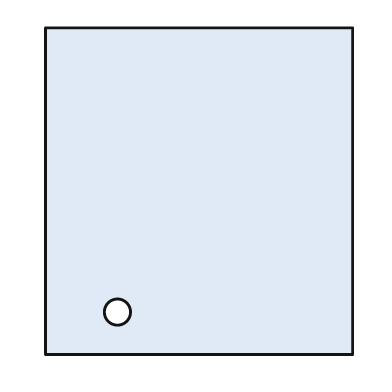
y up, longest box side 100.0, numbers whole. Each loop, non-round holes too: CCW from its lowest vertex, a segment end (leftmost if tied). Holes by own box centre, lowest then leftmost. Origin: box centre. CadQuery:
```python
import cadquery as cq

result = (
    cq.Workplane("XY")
    .moveTo(-47.0, -50.0)
    .lineTo(47.0, -50.0)
    .lineTo(47.0, 50.0)
    .lineTo(-47.0, 50.0)
    .close()
    .moveTo(-25.0, -37.0)
    .circle(4.0)
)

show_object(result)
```